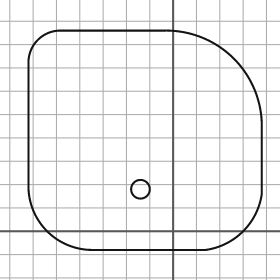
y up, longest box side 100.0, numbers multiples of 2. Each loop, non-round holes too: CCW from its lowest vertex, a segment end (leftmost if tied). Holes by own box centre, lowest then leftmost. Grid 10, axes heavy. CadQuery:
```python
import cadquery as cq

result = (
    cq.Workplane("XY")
    .moveTo(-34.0, -8.0)
    .lineTo(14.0, -8.0)
    .threePointArc((30.0, 0.0), (38.0, 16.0))
    .lineTo(38.0, 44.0)
    .threePointArc((26.0, 74.0), (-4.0, 86.0))
    .lineTo(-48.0, 86.0)
    .threePointArc((-58.0, 82.0), (-62.0, 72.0))
    .lineTo(-62.0, 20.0)
    .threePointArc((-54.0, 0.0), (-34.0, -8.0))
    .close()
    .moveTo(-14.0, 18.0)
    .circle(4.0)
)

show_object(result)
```